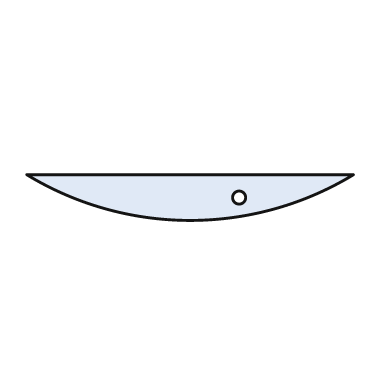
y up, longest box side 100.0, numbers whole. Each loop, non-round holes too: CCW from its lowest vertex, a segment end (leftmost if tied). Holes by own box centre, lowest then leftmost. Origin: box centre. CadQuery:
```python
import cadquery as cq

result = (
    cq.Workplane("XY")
    .moveTo(-50.0, 7.0)
    .threePointArc((0.0, -7.0), (50.0, 7.0))
    .close()
    .moveTo(15.0, 0.0)
    .circle(2.0)
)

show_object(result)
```